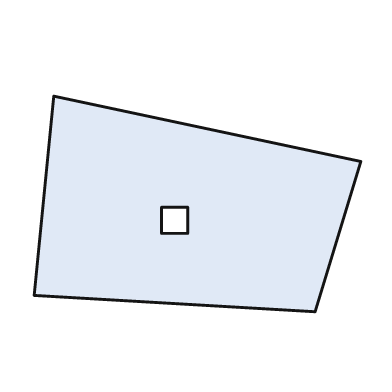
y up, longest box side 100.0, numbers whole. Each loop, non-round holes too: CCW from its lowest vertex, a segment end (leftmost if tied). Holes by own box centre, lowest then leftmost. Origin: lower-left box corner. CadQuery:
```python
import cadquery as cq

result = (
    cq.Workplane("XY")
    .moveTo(86.0, 0.0)
    .lineTo(100.0, 46.0)
    .lineTo(6.0, 66.0)
    .lineTo(0.0, 5.0)
    .close()
    .moveTo(39.0, 24.0)
    .lineTo(47.0, 24.0)
    .lineTo(47.0, 32.0)
    .lineTo(39.0, 32.0)
    .close()
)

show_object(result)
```